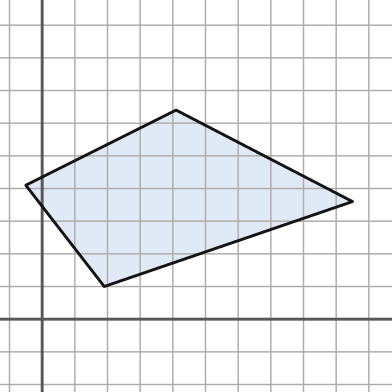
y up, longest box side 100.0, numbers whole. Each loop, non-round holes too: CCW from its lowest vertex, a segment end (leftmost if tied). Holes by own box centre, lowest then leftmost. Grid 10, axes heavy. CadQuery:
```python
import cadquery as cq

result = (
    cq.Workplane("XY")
    .moveTo(19.0, 10.0)
    .lineTo(95.0, 36.0)
    .lineTo(41.0, 64.0)
    .lineTo(-5.0, 41.0)
    .close()
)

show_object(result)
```